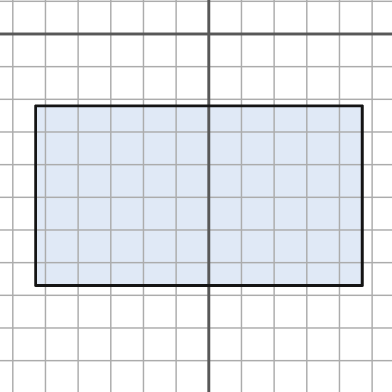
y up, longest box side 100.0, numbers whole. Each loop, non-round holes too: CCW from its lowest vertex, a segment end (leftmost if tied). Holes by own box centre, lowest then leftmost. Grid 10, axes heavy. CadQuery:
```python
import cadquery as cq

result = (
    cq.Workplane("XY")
    .moveTo(-53.0, -77.0)
    .lineTo(47.0, -77.0)
    .lineTo(47.0, -22.0)
    .lineTo(-53.0, -22.0)
    .close()
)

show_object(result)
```